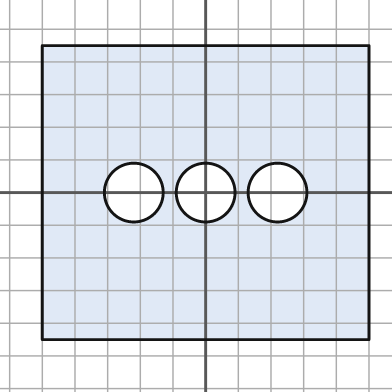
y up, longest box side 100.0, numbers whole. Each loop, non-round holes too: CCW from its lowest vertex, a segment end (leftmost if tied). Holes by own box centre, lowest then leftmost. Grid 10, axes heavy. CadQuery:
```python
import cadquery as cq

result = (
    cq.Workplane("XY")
    .moveTo(-50.0, -45.0)
    .lineTo(50.0, -45.0)
    .lineTo(50.0, 45.0)
    .lineTo(-50.0, 45.0)
    .close()
    .moveTo(-22.0, 0.0)
    .circle(9.0)
    .moveTo(0.0, 0.0)
    .circle(9.0)
    .moveTo(22.0, 0.0)
    .circle(9.0)
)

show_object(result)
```